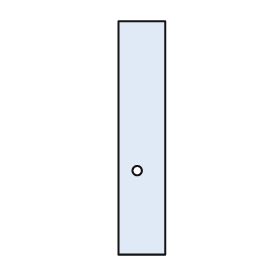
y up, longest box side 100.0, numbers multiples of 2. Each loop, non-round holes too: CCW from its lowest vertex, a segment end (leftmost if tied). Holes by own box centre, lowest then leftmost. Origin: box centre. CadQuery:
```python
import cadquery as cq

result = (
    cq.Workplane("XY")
    .moveTo(-10.0, -50.0)
    .lineTo(10.0, -50.0)
    .lineTo(10.0, 50.0)
    .lineTo(-10.0, 50.0)
    .close()
    .moveTo(-2.0, -14.0)
    .circle(2.0)
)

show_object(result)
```